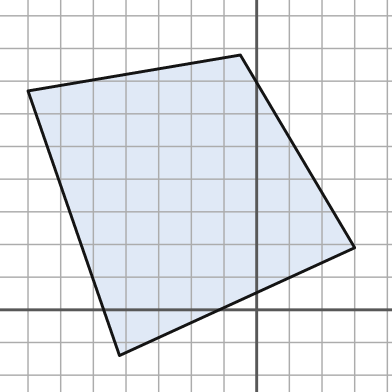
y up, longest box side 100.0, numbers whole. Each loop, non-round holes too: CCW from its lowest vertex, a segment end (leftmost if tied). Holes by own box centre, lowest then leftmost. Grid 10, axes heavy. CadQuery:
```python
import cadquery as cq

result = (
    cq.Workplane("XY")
    .moveTo(-42.0, -14.0)
    .lineTo(30.0, 19.0)
    .lineTo(-5.0, 78.0)
    .lineTo(-70.0, 67.0)
    .close()
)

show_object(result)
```